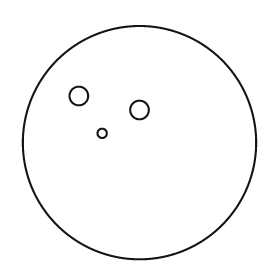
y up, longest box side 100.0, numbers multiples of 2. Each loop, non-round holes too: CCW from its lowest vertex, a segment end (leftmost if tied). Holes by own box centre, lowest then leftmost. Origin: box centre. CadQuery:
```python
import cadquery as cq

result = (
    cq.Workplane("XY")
    .moveTo(0.0, 0.0)
    .circle(50.0)
    .moveTo(-16.0, 4.0)
    .circle(2.0)
    .moveTo(0.0, 14.0)
    .circle(4.0)
    .moveTo(-26.0, 20.0)
    .circle(4.0)
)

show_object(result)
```